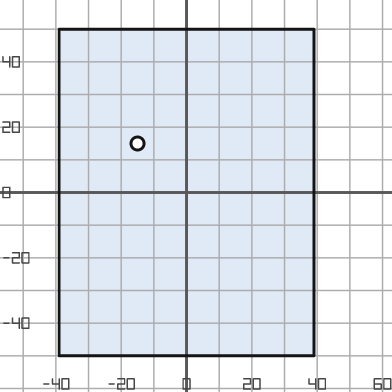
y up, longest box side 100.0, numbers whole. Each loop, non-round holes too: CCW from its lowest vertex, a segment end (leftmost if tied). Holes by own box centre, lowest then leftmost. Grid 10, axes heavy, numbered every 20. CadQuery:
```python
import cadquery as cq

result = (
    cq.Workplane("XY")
    .moveTo(-39.0, -50.0)
    .lineTo(39.0, -50.0)
    .lineTo(39.0, 50.0)
    .lineTo(-39.0, 50.0)
    .close()
    .moveTo(-15.0, 15.0)
    .circle(2.0)
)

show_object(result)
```